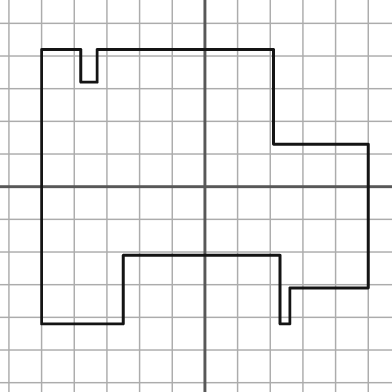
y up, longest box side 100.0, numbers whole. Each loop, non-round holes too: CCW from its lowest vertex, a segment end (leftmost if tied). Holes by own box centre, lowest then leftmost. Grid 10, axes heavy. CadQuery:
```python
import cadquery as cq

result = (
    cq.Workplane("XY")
    .moveTo(-50.0, -42.0)
    .lineTo(-25.0, -42.0)
    .lineTo(-25.0, -21.0)
    .lineTo(23.0, -21.0)
    .lineTo(23.0, -42.0)
    .lineTo(26.0, -42.0)
    .lineTo(26.0, -31.0)
    .lineTo(50.0, -31.0)
    .lineTo(50.0, 13.0)
    .lineTo(21.0, 13.0)
    .lineTo(21.0, 42.0)
    .lineTo(-33.0, 42.0)
    .lineTo(-33.0, 32.0)
    .lineTo(-38.0, 32.0)
    .lineTo(-38.0, 42.0)
    .lineTo(-50.0, 42.0)
    .close()
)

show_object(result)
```